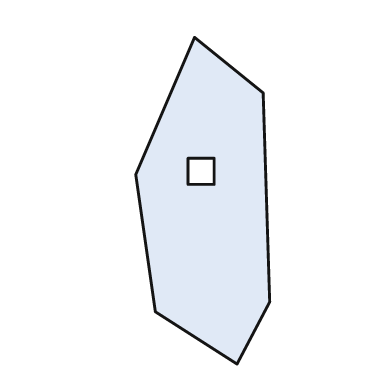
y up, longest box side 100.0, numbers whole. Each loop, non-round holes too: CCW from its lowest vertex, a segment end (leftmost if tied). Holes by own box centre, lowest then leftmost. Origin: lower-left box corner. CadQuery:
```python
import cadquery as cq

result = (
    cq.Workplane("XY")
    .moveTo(31.0, 0.0)
    .lineTo(41.0, 19.0)
    .lineTo(39.0, 83.0)
    .lineTo(18.0, 100.0)
    .lineTo(0.0, 58.0)
    .lineTo(6.0, 16.0)
    .close()
    .moveTo(16.0, 55.0)
    .lineTo(24.0, 55.0)
    .lineTo(24.0, 63.0)
    .lineTo(16.0, 63.0)
    .close()
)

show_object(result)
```